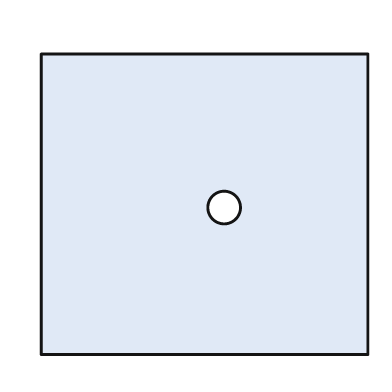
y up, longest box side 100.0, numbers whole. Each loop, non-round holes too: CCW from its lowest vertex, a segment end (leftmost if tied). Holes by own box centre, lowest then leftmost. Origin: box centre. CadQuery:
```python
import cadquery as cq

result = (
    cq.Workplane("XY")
    .moveTo(-50.0, -46.0)
    .lineTo(50.0, -46.0)
    .lineTo(50.0, 46.0)
    .lineTo(-50.0, 46.0)
    .close()
    .moveTo(6.0, -1.0)
    .circle(5.0)
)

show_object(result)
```